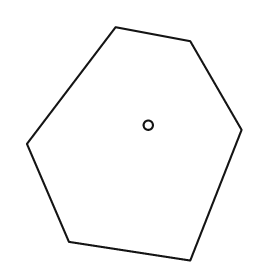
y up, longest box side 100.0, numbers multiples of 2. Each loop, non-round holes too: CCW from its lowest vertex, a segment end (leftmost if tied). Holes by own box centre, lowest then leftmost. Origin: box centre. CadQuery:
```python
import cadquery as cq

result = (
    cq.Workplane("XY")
    .moveTo(24.0, -50.0)
    .lineTo(46.0, 6.0)
    .lineTo(24.0, 44.0)
    .lineTo(-8.0, 50.0)
    .lineTo(-46.0, 0.0)
    .lineTo(-28.0, -42.0)
    .close()
    .moveTo(6.0, 8.0)
    .circle(2.0)
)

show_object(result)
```